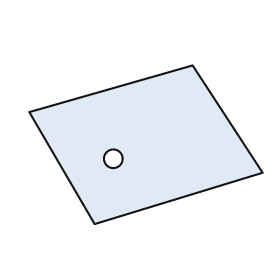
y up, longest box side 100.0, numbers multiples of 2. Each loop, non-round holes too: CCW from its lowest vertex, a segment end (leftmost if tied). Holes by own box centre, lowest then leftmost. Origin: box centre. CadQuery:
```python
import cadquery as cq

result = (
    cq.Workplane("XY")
    .moveTo(-22.0, -34.0)
    .lineTo(50.0, -12.0)
    .lineTo(20.0, 34.0)
    .lineTo(-50.0, 14.0)
    .close()
    .moveTo(-14.0, -6.0)
    .circle(4.0)
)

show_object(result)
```